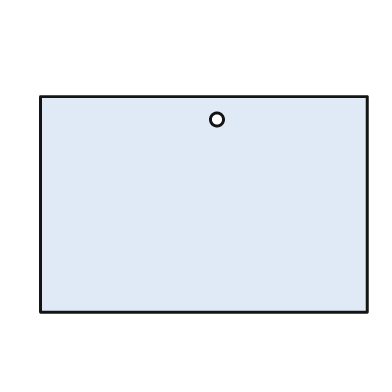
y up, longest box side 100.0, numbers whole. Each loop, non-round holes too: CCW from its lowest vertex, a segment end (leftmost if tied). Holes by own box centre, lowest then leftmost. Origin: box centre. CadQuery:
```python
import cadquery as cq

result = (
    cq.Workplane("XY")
    .moveTo(-50.0, -33.0)
    .lineTo(50.0, -33.0)
    .lineTo(50.0, 33.0)
    .lineTo(-50.0, 33.0)
    .close()
    .moveTo(4.0, 26.0)
    .circle(2.0)
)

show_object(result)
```